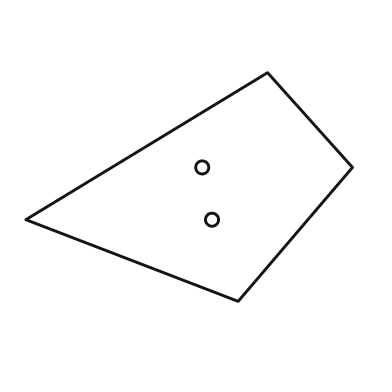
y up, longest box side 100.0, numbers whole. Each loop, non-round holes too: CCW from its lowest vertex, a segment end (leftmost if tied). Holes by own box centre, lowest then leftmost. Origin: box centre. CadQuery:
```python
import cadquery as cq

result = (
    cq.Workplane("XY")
    .moveTo(15.0, -35.0)
    .lineTo(50.0, 6.0)
    .lineTo(24.0, 35.0)
    .lineTo(-50.0, -10.0)
    .close()
    .moveTo(7.0, -10.0)
    .circle(2.0)
    .moveTo(4.0, 6.0)
    .circle(2.0)
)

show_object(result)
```